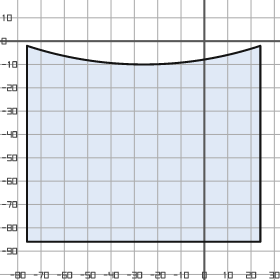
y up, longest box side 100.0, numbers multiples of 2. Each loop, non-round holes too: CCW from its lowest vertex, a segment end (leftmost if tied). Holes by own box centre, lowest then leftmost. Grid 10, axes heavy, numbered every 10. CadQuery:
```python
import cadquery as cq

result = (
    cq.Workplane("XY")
    .moveTo(-76.0, -86.0)
    .lineTo(24.0, -86.0)
    .lineTo(24.0, -2.0)
    .threePointArc((-26.0, -10.0), (-76.0, -2.0))
    .close()
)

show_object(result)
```